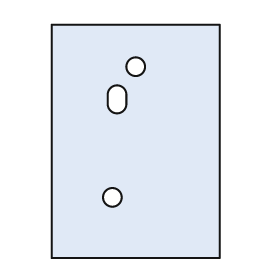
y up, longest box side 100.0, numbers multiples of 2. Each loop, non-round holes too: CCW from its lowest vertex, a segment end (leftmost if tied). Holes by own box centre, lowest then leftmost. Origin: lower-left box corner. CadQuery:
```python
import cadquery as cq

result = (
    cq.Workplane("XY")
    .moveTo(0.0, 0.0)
    .lineTo(72.0, 0.0)
    .lineTo(72.0, 100.0)
    .lineTo(0.0, 100.0)
    .close()
    .moveTo(26.0, 26.0)
    .circle(4.0)
    .moveTo(24.0, 66.0)
    .threePointArc((28.0, 62.0), (32.0, 66.0))
    .lineTo(32.0, 70.0)
    .threePointArc((28.0, 74.0), (24.0, 70.0))
    .close()
    .moveTo(36.0, 82.0)
    .circle(4.0)
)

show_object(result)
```